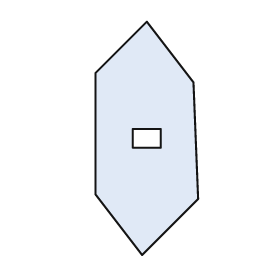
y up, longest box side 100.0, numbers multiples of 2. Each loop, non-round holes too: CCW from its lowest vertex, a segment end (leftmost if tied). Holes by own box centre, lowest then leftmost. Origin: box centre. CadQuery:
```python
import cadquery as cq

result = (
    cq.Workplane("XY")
    .moveTo(-2.0, -50.0)
    .lineTo(22.0, -26.0)
    .lineTo(20.0, 24.0)
    .lineTo(0.0, 50.0)
    .lineTo(-22.0, 28.0)
    .lineTo(-22.0, -24.0)
    .close()
    .moveTo(-6.0, -4.0)
    .lineTo(6.0, -4.0)
    .lineTo(6.0, 4.0)
    .lineTo(-6.0, 4.0)
    .close()
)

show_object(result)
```